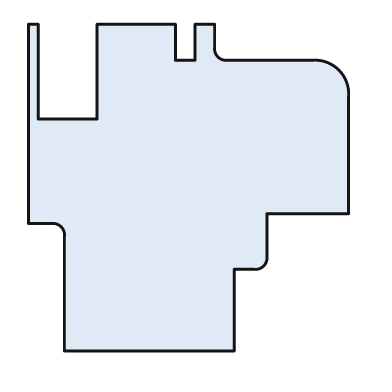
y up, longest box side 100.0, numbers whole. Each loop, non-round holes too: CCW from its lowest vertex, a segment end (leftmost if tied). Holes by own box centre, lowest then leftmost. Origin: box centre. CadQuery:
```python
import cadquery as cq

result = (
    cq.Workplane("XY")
    .moveTo(-38.0, -50.0)
    .lineTo(14.0, -50.0)
    .lineTo(14.0, -25.0)
    .lineTo(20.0, -25.0)
    .threePointArc((23.0, -24.0), (24.0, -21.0))
    .lineTo(24.0, -8.0)
    .lineTo(49.0, -8.0)
    .lineTo(49.0, 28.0)
    .threePointArc((46.0, 36.0), (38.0, 39.0))
    .lineTo(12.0, 39.0)
    .threePointArc((9.0, 40.0), (8.0, 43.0))
    .lineTo(8.0, 50.0)
    .lineTo(2.0, 50.0)
    .lineTo(2.0, 39.0)
    .lineTo(-4.0, 39.0)
    .lineTo(-4.0, 50.0)
    .lineTo(-28.0, 50.0)
    .lineTo(-28.0, 21.0)
    .lineTo(-46.0, 21.0)
    .lineTo(-46.0, 50.0)
    .lineTo(-49.0, 50.0)
    .lineTo(-49.0, -11.0)
    .lineTo(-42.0, -11.0)
    .threePointArc((-39.0, -12.0), (-38.0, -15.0))
    .close()
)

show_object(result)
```